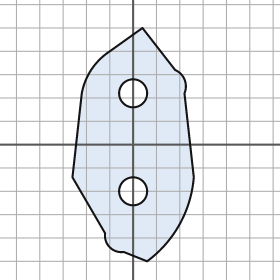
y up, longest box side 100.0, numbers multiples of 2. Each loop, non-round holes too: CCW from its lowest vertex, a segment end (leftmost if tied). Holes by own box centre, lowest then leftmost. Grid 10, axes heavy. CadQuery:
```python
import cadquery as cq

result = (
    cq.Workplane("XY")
    .moveTo(6.0, -50.0)
    .threePointArc((20.0, -34.0), (26.0, -14.0))
    .lineTo(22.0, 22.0)
    .threePointArc((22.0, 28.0), (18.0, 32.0))
    .lineTo(4.0, 50.0)
    .lineTo(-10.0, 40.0)
    .threePointArc((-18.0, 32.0), (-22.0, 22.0))
    .lineTo(-26.0, -14.0)
    .lineTo(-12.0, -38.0)
    .threePointArc((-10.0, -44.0), (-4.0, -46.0))
    .close()
    .moveTo(0.0, -20.0)
    .circle(6.0)
    .moveTo(0.0, 22.0)
    .circle(6.0)
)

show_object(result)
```